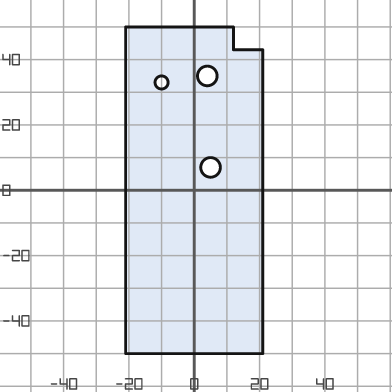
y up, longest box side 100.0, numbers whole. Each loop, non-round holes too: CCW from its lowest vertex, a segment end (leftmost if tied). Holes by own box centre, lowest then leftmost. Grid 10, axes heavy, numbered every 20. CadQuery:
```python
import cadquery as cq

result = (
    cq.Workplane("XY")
    .moveTo(-21.0, -50.0)
    .lineTo(21.0, -50.0)
    .lineTo(21.0, 43.0)
    .lineTo(12.0, 43.0)
    .lineTo(12.0, 50.0)
    .lineTo(-21.0, 50.0)
    .close()
    .moveTo(5.0, 7.0)
    .circle(3.0)
    .moveTo(-10.0, 33.0)
    .circle(2.0)
    .moveTo(4.0, 35.0)
    .circle(3.0)
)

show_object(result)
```